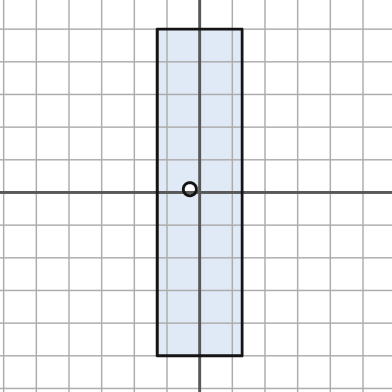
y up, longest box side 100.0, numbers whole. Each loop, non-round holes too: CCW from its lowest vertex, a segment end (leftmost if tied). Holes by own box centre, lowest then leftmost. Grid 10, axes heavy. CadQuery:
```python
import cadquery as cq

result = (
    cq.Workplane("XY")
    .moveTo(-13.0, -50.0)
    .lineTo(13.0, -50.0)
    .lineTo(13.0, 50.0)
    .lineTo(-13.0, 50.0)
    .close()
    .moveTo(-3.0, 1.0)
    .circle(2.0)
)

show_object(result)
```